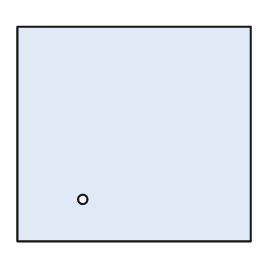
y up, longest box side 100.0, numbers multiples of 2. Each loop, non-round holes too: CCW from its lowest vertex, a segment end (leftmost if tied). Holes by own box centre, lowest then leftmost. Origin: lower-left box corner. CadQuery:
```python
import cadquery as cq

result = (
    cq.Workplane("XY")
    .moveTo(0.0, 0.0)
    .lineTo(100.0, 0.0)
    .lineTo(100.0, 92.0)
    .lineTo(0.0, 92.0)
    .close()
    .moveTo(28.0, 18.0)
    .circle(2.0)
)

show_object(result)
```